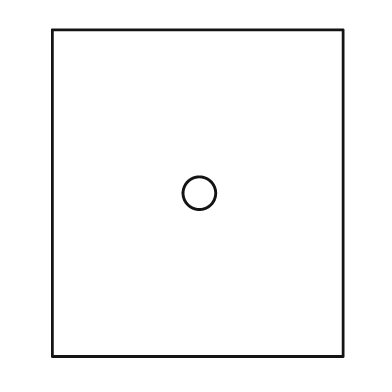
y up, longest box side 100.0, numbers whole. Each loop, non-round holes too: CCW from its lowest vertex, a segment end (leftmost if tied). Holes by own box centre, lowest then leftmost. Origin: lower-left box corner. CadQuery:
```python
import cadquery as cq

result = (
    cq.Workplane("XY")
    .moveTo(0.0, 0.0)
    .lineTo(89.0, 0.0)
    .lineTo(89.0, 100.0)
    .lineTo(0.0, 100.0)
    .close()
    .moveTo(45.0, 50.0)
    .circle(5.0)
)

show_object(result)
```